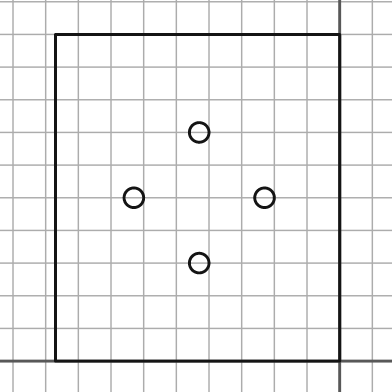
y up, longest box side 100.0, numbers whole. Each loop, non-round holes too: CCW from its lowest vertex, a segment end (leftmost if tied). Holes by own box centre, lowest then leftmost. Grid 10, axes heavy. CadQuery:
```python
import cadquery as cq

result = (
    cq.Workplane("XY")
    .moveTo(-87.0, 0.0)
    .lineTo(0.0, 0.0)
    .lineTo(0.0, 100.0)
    .lineTo(-87.0, 100.0)
    .close()
    .moveTo(-43.0, 30.0)
    .circle(3.0)
    .moveTo(-63.0, 50.0)
    .circle(3.0)
    .moveTo(-23.0, 50.0)
    .circle(3.0)
    .moveTo(-43.0, 70.0)
    .circle(3.0)
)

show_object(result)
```